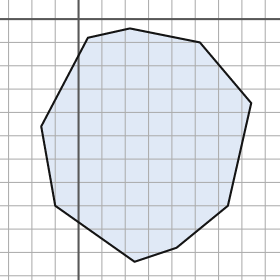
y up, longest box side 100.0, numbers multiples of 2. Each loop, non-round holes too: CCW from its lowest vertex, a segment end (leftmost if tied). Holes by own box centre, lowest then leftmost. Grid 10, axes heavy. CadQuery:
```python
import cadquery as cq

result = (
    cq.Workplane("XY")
    .moveTo(24.0, -104.0)
    .lineTo(42.0, -98.0)
    .lineTo(64.0, -80.0)
    .lineTo(74.0, -36.0)
    .lineTo(52.0, -10.0)
    .lineTo(22.0, -4.0)
    .lineTo(4.0, -8.0)
    .lineTo(-16.0, -46.0)
    .lineTo(-10.0, -80.0)
    .close()
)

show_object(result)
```